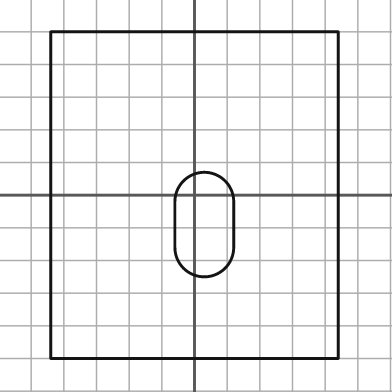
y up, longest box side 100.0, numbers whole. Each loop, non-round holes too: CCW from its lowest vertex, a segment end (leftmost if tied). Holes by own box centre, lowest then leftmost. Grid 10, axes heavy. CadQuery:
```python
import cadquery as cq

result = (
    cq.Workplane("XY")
    .moveTo(-44.0, -50.0)
    .lineTo(44.0, -50.0)
    .lineTo(44.0, 50.0)
    .lineTo(-44.0, 50.0)
    .close()
    .moveTo(-6.0, -16.0)
    .threePointArc((3.0, -25.0), (12.0, -16.0))
    .lineTo(12.0, -2.0)
    .threePointArc((3.0, 7.0), (-6.0, -2.0))
    .close()
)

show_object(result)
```